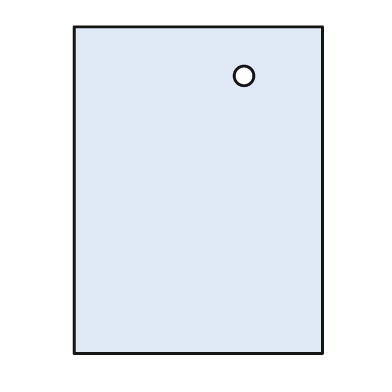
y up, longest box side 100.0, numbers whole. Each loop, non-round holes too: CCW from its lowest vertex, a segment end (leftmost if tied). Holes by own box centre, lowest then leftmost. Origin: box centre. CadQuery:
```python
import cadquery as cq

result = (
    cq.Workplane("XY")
    .moveTo(-38.0, -50.0)
    .lineTo(38.0, -50.0)
    .lineTo(38.0, 50.0)
    .lineTo(-38.0, 50.0)
    .close()
    .moveTo(14.0, 35.0)
    .circle(3.0)
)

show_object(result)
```